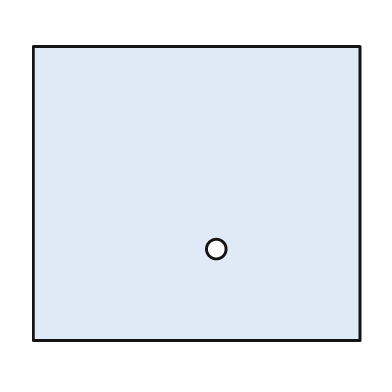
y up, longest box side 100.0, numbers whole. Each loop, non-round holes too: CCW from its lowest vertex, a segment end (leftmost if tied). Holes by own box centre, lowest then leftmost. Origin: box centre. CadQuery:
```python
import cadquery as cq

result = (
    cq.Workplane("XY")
    .moveTo(-50.0, -45.0)
    .lineTo(50.0, -45.0)
    .lineTo(50.0, 45.0)
    .lineTo(-50.0, 45.0)
    .close()
    .moveTo(6.0, -17.0)
    .circle(3.0)
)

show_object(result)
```